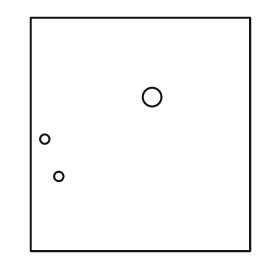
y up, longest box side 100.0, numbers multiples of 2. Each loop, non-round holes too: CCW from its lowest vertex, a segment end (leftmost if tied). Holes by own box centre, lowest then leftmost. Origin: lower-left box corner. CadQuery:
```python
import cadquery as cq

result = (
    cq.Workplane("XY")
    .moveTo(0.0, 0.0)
    .lineTo(94.0, 0.0)
    .lineTo(94.0, 100.0)
    .lineTo(0.0, 100.0)
    .close()
    .moveTo(12.0, 32.0)
    .circle(2.0)
    .moveTo(6.0, 48.0)
    .circle(2.0)
    .moveTo(52.0, 66.0)
    .circle(4.0)
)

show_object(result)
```